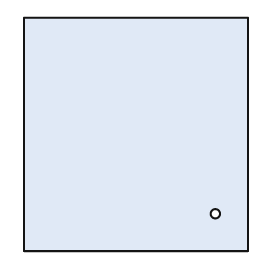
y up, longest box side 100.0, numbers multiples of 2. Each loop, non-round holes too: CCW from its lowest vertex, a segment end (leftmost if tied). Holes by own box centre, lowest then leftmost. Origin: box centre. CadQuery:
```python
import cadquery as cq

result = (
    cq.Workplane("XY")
    .moveTo(-48.0, -50.0)
    .lineTo(48.0, -50.0)
    .lineTo(48.0, 50.0)
    .lineTo(-48.0, 50.0)
    .close()
    .moveTo(34.0, -34.0)
    .circle(2.0)
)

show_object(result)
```